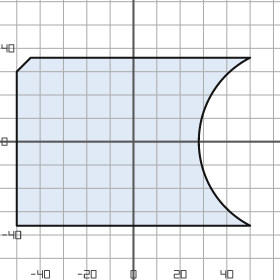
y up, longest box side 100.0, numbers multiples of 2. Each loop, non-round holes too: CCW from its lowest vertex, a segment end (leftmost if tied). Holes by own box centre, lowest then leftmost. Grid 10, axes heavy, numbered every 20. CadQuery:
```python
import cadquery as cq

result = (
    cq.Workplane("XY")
    .moveTo(-50.0, -36.0)
    .lineTo(50.0, -36.0)
    .threePointArc((28.0, 0.0), (50.0, 36.0))
    .lineTo(-44.0, 36.0)
    .lineTo(-50.0, 30.0)
    .close()
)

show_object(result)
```